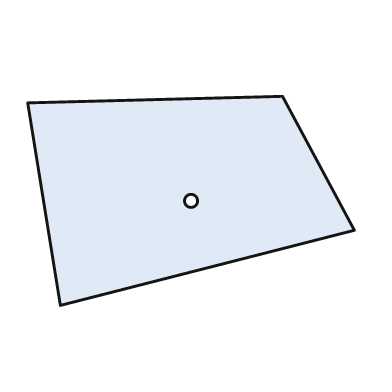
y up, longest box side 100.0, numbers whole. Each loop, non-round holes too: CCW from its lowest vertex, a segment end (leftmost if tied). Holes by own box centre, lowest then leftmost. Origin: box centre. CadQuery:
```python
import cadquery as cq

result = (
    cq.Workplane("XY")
    .moveTo(-40.0, -32.0)
    .lineTo(50.0, -9.0)
    .lineTo(28.0, 32.0)
    .lineTo(-50.0, 30.0)
    .close()
    .moveTo(0.0, 0.0)
    .circle(2.0)
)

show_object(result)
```